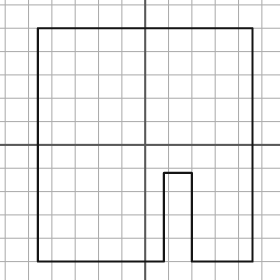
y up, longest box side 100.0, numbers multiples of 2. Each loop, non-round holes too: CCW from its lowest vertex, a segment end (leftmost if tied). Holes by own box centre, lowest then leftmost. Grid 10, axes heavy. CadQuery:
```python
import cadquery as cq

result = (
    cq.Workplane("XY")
    .moveTo(-46.0, -50.0)
    .lineTo(8.0, -50.0)
    .lineTo(8.0, -12.0)
    .lineTo(20.0, -12.0)
    .lineTo(20.0, -50.0)
    .lineTo(46.0, -50.0)
    .lineTo(46.0, 50.0)
    .lineTo(-46.0, 50.0)
    .close()
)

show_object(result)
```